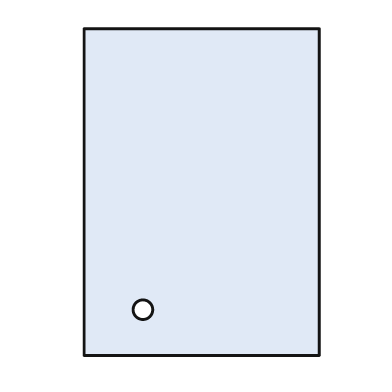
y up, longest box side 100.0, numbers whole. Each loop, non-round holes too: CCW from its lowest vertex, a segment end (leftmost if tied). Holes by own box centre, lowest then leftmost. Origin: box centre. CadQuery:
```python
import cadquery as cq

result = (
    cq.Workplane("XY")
    .moveTo(-36.0, -50.0)
    .lineTo(36.0, -50.0)
    .lineTo(36.0, 50.0)
    .lineTo(-36.0, 50.0)
    .close()
    .moveTo(-18.0, -36.0)
    .circle(3.0)
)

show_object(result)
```